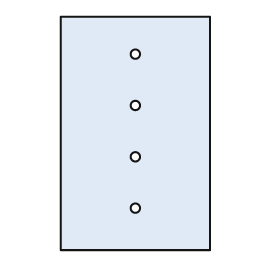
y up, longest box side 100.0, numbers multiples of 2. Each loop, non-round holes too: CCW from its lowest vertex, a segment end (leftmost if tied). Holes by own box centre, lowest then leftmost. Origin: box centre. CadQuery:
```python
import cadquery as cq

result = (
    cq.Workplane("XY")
    .moveTo(-32.0, -50.0)
    .lineTo(32.0, -50.0)
    .lineTo(32.0, 50.0)
    .lineTo(-32.0, 50.0)
    .close()
    .moveTo(0.0, -32.0)
    .circle(2.0)
    .moveTo(0.0, -10.0)
    .circle(2.0)
    .moveTo(0.0, 12.0)
    .circle(2.0)
    .moveTo(0.0, 34.0)
    .circle(2.0)
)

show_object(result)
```